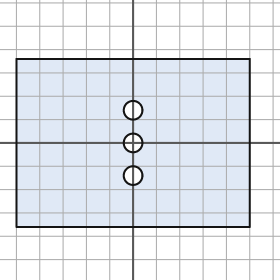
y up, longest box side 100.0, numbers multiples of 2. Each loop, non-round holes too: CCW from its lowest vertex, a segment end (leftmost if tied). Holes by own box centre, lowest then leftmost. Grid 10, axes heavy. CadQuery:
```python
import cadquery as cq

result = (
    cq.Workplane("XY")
    .moveTo(-50.0, -36.0)
    .lineTo(50.0, -36.0)
    .lineTo(50.0, 36.0)
    .lineTo(-50.0, 36.0)
    .close()
    .moveTo(0.0, -14.0)
    .circle(4.0)
    .moveTo(0.0, 0.0)
    .circle(4.0)
    .moveTo(0.0, 14.0)
    .circle(4.0)
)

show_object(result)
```